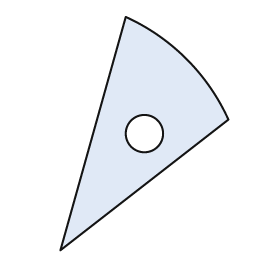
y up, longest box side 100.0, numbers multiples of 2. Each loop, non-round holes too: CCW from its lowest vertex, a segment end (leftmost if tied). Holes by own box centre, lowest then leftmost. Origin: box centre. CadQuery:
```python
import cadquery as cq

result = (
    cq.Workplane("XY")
    .moveTo(-36.0, -50.0)
    .lineTo(36.0, 6.0)
    .threePointArc((18.0, 32.0), (-8.0, 50.0))
    .close()
    .moveTo(0.0, 0.0)
    .circle(8.0)
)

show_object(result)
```